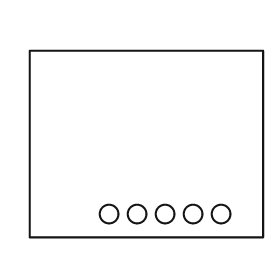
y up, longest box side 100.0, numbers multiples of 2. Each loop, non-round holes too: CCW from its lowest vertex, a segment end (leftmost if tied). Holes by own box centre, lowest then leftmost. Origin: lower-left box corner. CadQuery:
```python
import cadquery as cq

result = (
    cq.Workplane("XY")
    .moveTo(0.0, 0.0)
    .lineTo(100.0, 0.0)
    .lineTo(100.0, 80.0)
    .lineTo(0.0, 80.0)
    .close()
    .moveTo(34.0, 10.0)
    .circle(4.0)
    .moveTo(46.0, 10.0)
    .circle(4.0)
    .moveTo(58.0, 10.0)
    .circle(4.0)
    .moveTo(70.0, 10.0)
    .circle(4.0)
    .moveTo(82.0, 10.0)
    .circle(4.0)
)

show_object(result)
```